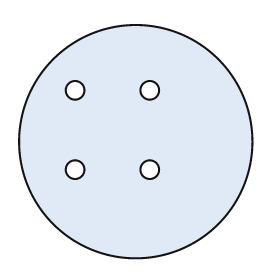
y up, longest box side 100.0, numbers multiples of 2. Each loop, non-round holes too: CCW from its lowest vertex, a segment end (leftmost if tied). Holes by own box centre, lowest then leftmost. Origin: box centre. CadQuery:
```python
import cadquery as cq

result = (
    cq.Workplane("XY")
    .moveTo(0.0, 0.0)
    .circle(50.0)
    .moveTo(-26.0, -12.0)
    .circle(4.0)
    .moveTo(6.0, -12.0)
    .circle(4.0)
    .moveTo(-26.0, 22.0)
    .circle(4.0)
    .moveTo(6.0, 22.0)
    .circle(4.0)
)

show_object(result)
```